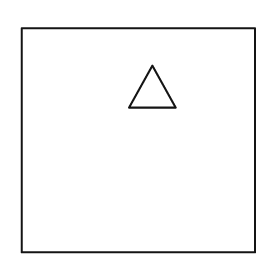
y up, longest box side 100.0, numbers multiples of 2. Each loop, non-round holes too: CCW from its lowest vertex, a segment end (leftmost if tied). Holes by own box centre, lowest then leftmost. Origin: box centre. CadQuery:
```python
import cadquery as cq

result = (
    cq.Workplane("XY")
    .moveTo(-50.0, -48.0)
    .lineTo(50.0, -48.0)
    .lineTo(50.0, 48.0)
    .lineTo(-50.0, 48.0)
    .close()
    .moveTo(-4.0, 14.0)
    .lineTo(16.0, 14.0)
    .lineTo(6.0, 32.0)
    .close()
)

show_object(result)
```